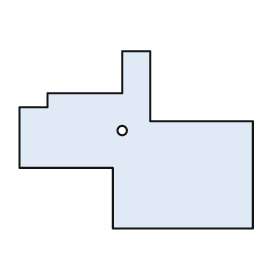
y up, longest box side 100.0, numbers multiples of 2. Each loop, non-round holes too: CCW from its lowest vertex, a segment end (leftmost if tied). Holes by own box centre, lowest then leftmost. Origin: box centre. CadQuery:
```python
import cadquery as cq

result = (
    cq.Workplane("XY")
    .moveTo(-10.0, -38.0)
    .lineTo(50.0, -38.0)
    .lineTo(50.0, 8.0)
    .lineTo(6.0, 8.0)
    .lineTo(6.0, 38.0)
    .lineTo(-6.0, 38.0)
    .lineTo(-6.0, 20.0)
    .lineTo(-38.0, 20.0)
    .lineTo(-38.0, 14.0)
    .lineTo(-50.0, 14.0)
    .lineTo(-50.0, -12.0)
    .lineTo(-10.0, -12.0)
    .close()
    .moveTo(-6.0, 4.0)
    .circle(2.0)
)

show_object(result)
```